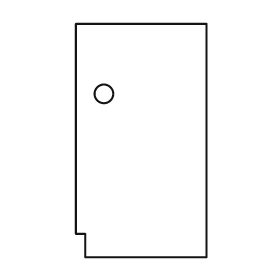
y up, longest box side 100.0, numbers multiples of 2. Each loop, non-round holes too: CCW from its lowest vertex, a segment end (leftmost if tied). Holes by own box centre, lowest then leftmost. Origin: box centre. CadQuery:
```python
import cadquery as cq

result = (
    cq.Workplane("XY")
    .moveTo(-24.0, -50.0)
    .lineTo(28.0, -50.0)
    .lineTo(28.0, 50.0)
    .lineTo(-28.0, 50.0)
    .lineTo(-28.0, -40.0)
    .lineTo(-24.0, -40.0)
    .close()
    .moveTo(-16.0, 20.0)
    .circle(4.0)
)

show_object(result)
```